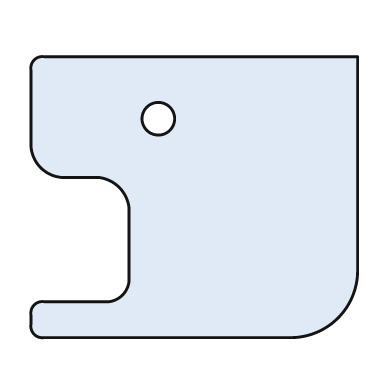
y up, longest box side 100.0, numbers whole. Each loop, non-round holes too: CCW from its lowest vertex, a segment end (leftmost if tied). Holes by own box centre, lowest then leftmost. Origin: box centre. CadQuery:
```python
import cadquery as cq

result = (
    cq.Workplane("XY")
    .moveTo(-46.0, -43.0)
    .lineTo(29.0, -43.0)
    .threePointArc((44.0, -37.0), (50.0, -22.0))
    .lineTo(50.0, 43.0)
    .lineTo(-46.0, 43.0)
    .threePointArc((-49.0, 42.0), (-50.0, 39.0))
    .lineTo(-50.0, 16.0)
    .threePointArc((-47.0, 9.0), (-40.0, 6.0))
    .lineTo(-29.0, 6.0)
    .threePointArc((-23.0, 3.0), (-20.0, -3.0))
    .lineTo(-20.0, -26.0)
    .threePointArc((-22.0, -30.0), (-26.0, -32.0))
    .lineTo(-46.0, -32.0)
    .threePointArc((-49.0, -33.0), (-50.0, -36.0))
    .lineTo(-50.0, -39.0)
    .threePointArc((-49.0, -42.0), (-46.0, -43.0))
    .close()
    .moveTo(-11.0, 24.0)
    .circle(5.0)
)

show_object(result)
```